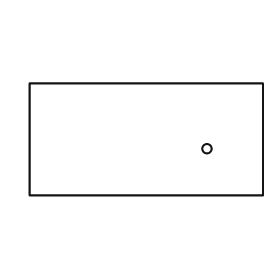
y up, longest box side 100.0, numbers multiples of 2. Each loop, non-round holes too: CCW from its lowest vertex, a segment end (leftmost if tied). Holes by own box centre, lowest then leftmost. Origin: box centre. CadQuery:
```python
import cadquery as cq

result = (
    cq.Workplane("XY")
    .moveTo(-50.0, -24.0)
    .lineTo(50.0, -24.0)
    .lineTo(50.0, 24.0)
    .lineTo(-50.0, 24.0)
    .close()
    .moveTo(26.0, -4.0)
    .circle(2.0)
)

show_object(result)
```